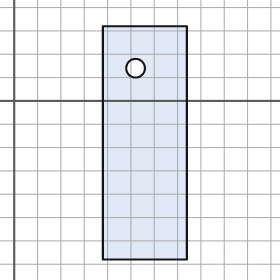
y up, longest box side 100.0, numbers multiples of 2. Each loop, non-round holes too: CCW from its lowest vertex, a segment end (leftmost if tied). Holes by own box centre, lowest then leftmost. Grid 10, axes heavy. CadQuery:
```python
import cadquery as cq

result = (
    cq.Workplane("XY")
    .moveTo(38.0, -68.0)
    .lineTo(74.0, -68.0)
    .lineTo(74.0, 32.0)
    .lineTo(38.0, 32.0)
    .close()
    .moveTo(52.0, 14.0)
    .circle(4.0)
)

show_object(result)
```